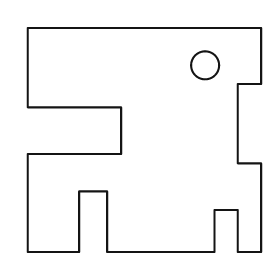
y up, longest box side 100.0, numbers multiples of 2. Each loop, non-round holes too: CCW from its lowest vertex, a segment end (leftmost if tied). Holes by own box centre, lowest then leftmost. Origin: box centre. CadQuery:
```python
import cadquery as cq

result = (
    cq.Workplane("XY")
    .moveTo(-50.0, -48.0)
    .lineTo(-28.0, -48.0)
    .lineTo(-28.0, -22.0)
    .lineTo(-16.0, -22.0)
    .lineTo(-16.0, -48.0)
    .lineTo(30.0, -48.0)
    .lineTo(30.0, -30.0)
    .lineTo(40.0, -30.0)
    .lineTo(40.0, -48.0)
    .lineTo(50.0, -48.0)
    .lineTo(50.0, -10.0)
    .lineTo(40.0, -10.0)
    .lineTo(40.0, 24.0)
    .lineTo(50.0, 24.0)
    .lineTo(50.0, 48.0)
    .lineTo(-50.0, 48.0)
    .lineTo(-50.0, 14.0)
    .lineTo(-10.0, 14.0)
    .lineTo(-10.0, -6.0)
    .lineTo(-50.0, -6.0)
    .close()
    .moveTo(26.0, 32.0)
    .circle(6.0)
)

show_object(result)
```